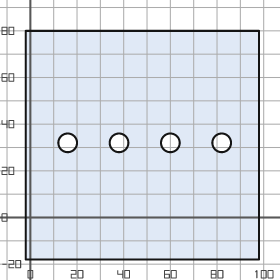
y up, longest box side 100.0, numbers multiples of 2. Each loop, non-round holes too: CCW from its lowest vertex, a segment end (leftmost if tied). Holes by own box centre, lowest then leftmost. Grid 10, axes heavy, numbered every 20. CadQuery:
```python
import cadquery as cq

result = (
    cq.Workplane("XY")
    .moveTo(-2.0, -18.0)
    .lineTo(98.0, -18.0)
    .lineTo(98.0, 80.0)
    .lineTo(-2.0, 80.0)
    .close()
    .moveTo(16.0, 32.0)
    .circle(4.0)
    .moveTo(38.0, 32.0)
    .circle(4.0)
    .moveTo(60.0, 32.0)
    .circle(4.0)
    .moveTo(82.0, 32.0)
    .circle(4.0)
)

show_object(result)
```